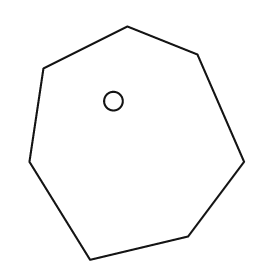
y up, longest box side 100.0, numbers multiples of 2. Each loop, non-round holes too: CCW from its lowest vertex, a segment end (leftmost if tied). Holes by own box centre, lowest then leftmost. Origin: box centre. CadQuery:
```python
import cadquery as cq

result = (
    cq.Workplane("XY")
    .moveTo(-20.0, -50.0)
    .lineTo(22.0, -40.0)
    .lineTo(46.0, -8.0)
    .lineTo(26.0, 38.0)
    .lineTo(-4.0, 50.0)
    .lineTo(-40.0, 32.0)
    .lineTo(-46.0, -8.0)
    .close()
    .moveTo(-10.0, 18.0)
    .circle(4.0)
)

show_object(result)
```